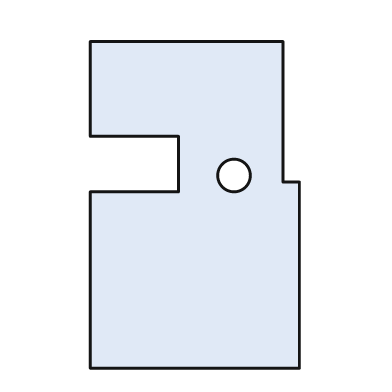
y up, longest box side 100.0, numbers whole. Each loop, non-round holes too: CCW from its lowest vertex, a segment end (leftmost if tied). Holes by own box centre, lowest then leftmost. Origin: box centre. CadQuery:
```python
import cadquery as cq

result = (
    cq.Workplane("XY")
    .moveTo(-32.0, -50.0)
    .lineTo(32.0, -50.0)
    .lineTo(32.0, 7.0)
    .lineTo(27.0, 7.0)
    .lineTo(27.0, 50.0)
    .lineTo(-32.0, 50.0)
    .lineTo(-32.0, 21.0)
    .lineTo(-5.0, 21.0)
    .lineTo(-5.0, 4.0)
    .lineTo(-32.0, 4.0)
    .close()
    .moveTo(12.0, 9.0)
    .circle(5.0)
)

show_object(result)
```